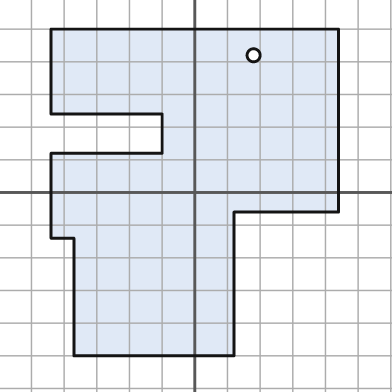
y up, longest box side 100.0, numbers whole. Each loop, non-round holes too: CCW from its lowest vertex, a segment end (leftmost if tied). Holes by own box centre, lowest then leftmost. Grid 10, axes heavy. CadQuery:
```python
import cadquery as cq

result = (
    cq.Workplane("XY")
    .moveTo(-37.0, -50.0)
    .lineTo(12.0, -50.0)
    .lineTo(12.0, -6.0)
    .lineTo(44.0, -6.0)
    .lineTo(44.0, 50.0)
    .lineTo(-44.0, 50.0)
    .lineTo(-44.0, 24.0)
    .lineTo(-10.0, 24.0)
    .lineTo(-10.0, 12.0)
    .lineTo(-44.0, 12.0)
    .lineTo(-44.0, -14.0)
    .lineTo(-37.0, -14.0)
    .close()
    .moveTo(18.0, 42.0)
    .circle(2.0)
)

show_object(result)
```